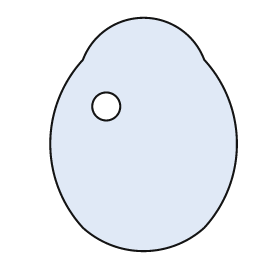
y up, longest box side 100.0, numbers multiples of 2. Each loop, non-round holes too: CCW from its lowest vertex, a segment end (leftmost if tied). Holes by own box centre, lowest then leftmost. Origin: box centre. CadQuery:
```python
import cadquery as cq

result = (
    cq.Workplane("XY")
    .moveTo(-26.0, -40.0)
    .threePointArc((0.0, -50.0), (26.0, -40.0))
    .threePointArc((40.0, -4.0), (26.0, 32.0))
    .threePointArc((0.0, 50.0), (-26.0, 32.0))
    .threePointArc((-40.0, -4.0), (-26.0, -40.0))
    .close()
    .moveTo(-16.0, 12.0)
    .circle(6.0)
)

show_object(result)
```